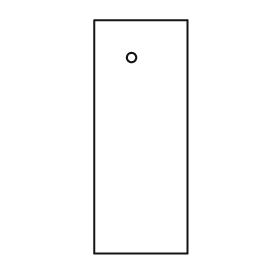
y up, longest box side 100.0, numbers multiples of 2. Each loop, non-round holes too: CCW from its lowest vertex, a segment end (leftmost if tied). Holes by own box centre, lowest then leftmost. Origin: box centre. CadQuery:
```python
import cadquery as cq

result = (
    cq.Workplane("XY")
    .moveTo(-20.0, -50.0)
    .lineTo(20.0, -50.0)
    .lineTo(20.0, 50.0)
    .lineTo(-20.0, 50.0)
    .close()
    .moveTo(-4.0, 34.0)
    .circle(2.0)
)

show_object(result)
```